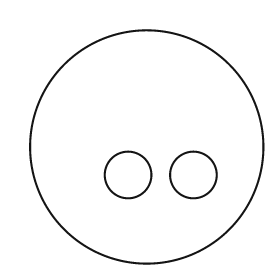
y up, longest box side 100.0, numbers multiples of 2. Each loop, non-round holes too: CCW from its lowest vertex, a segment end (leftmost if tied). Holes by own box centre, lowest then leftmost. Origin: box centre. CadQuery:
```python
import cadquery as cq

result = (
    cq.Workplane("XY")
    .moveTo(0.0, 0.0)
    .circle(50.0)
    .moveTo(-8.0, -12.0)
    .circle(10.0)
    .moveTo(20.0, -12.0)
    .circle(10.0)
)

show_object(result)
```